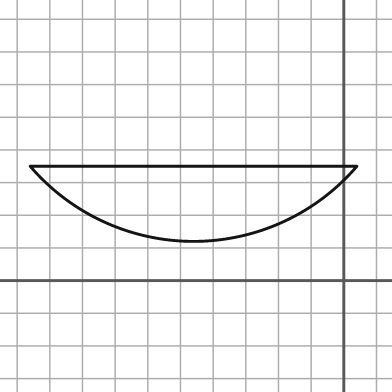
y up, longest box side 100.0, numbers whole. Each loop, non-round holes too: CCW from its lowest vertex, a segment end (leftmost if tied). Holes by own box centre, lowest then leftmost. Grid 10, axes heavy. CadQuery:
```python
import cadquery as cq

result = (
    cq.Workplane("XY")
    .moveTo(-96.0, 35.0)
    .threePointArc((-46.0, 12.0), (4.0, 35.0))
    .close()
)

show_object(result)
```